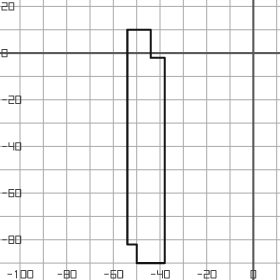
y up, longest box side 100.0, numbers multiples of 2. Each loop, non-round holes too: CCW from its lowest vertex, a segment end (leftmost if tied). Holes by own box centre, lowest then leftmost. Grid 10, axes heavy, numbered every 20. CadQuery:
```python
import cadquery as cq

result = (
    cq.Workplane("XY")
    .moveTo(-50.0, -90.0)
    .lineTo(-38.0, -90.0)
    .lineTo(-38.0, -2.0)
    .lineTo(-44.0, -2.0)
    .lineTo(-44.0, 10.0)
    .lineTo(-54.0, 10.0)
    .lineTo(-54.0, -82.0)
    .lineTo(-50.0, -82.0)
    .close()
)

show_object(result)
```